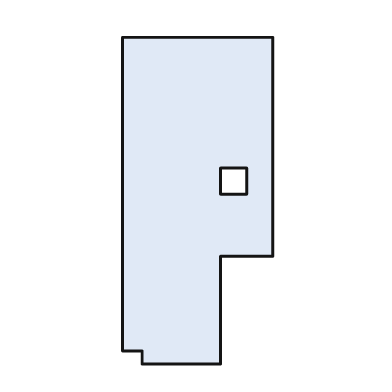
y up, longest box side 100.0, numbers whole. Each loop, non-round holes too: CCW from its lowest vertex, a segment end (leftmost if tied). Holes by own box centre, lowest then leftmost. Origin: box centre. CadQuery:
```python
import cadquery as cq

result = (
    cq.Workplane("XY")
    .moveTo(-17.0, -50.0)
    .lineTo(7.0, -50.0)
    .lineTo(7.0, -17.0)
    .lineTo(23.0, -17.0)
    .lineTo(23.0, 50.0)
    .lineTo(-23.0, 50.0)
    .lineTo(-23.0, -46.0)
    .lineTo(-17.0, -46.0)
    .close()
    .moveTo(7.0, 2.0)
    .lineTo(15.0, 2.0)
    .lineTo(15.0, 10.0)
    .lineTo(7.0, 10.0)
    .close()
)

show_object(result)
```